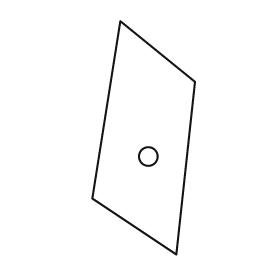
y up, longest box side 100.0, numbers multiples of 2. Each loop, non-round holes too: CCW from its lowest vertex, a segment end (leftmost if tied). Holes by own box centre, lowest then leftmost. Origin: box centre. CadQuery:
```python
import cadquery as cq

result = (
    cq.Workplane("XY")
    .moveTo(14.0, -50.0)
    .lineTo(22.0, 24.0)
    .lineTo(-10.0, 50.0)
    .lineTo(-22.0, -26.0)
    .close()
    .moveTo(2.0, -8.0)
    .circle(4.0)
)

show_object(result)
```